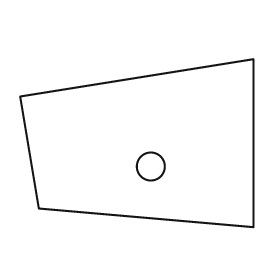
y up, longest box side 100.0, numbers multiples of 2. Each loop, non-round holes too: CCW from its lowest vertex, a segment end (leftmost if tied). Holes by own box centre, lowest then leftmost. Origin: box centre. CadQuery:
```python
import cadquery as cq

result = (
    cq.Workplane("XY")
    .moveTo(50.0, -36.0)
    .lineTo(50.0, 36.0)
    .lineTo(-50.0, 20.0)
    .lineTo(-42.0, -28.0)
    .close()
    .moveTo(6.0, -10.0)
    .circle(6.0)
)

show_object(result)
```